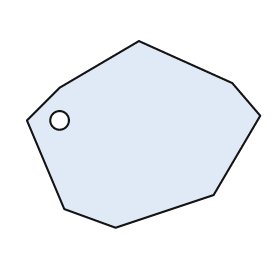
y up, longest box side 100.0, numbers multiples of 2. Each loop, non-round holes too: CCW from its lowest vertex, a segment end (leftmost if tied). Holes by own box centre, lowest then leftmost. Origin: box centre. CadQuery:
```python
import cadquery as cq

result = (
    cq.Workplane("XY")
    .moveTo(-12.0, -40.0)
    .lineTo(30.0, -26.0)
    .lineTo(50.0, 8.0)
    .lineTo(38.0, 22.0)
    .lineTo(-2.0, 40.0)
    .lineTo(-36.0, 20.0)
    .lineTo(-50.0, 6.0)
    .lineTo(-34.0, -32.0)
    .close()
    .moveTo(-36.0, 6.0)
    .circle(4.0)
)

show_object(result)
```